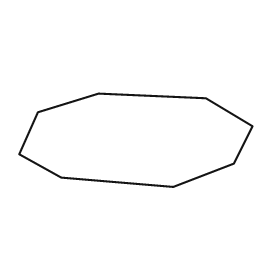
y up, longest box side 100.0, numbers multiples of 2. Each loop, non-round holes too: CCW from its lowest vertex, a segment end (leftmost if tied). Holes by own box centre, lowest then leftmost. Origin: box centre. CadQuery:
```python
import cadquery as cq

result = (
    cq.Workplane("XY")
    .moveTo(16.0, -20.0)
    .lineTo(42.0, -10.0)
    .lineTo(50.0, 6.0)
    .lineTo(30.0, 18.0)
    .lineTo(-16.0, 20.0)
    .lineTo(-42.0, 12.0)
    .lineTo(-50.0, -6.0)
    .lineTo(-32.0, -16.0)
    .close()
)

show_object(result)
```